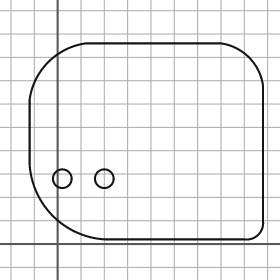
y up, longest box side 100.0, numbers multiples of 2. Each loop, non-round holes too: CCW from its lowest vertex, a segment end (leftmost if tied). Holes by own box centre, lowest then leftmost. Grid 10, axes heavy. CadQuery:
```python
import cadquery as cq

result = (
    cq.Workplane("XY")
    .moveTo(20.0, 2.0)
    .lineTo(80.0, 2.0)
    .threePointArc((86.0, 4.0), (88.0, 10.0))
    .lineTo(88.0, 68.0)
    .threePointArc((82.0, 80.0), (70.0, 86.0))
    .lineTo(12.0, 86.0)
    .threePointArc((-4.0, 78.0), (-12.0, 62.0))
    .lineTo(-12.0, 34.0)
    .threePointArc((-2.0, 12.0), (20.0, 2.0))
    .close()
    .moveTo(2.0, 28.0)
    .circle(4.0)
    .moveTo(20.0, 28.0)
    .circle(4.0)
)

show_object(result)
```